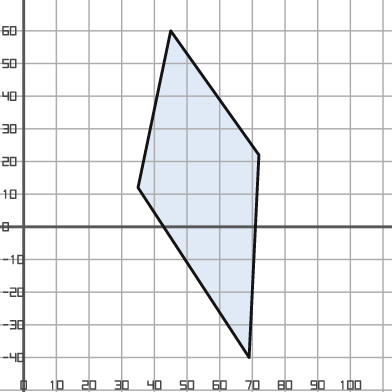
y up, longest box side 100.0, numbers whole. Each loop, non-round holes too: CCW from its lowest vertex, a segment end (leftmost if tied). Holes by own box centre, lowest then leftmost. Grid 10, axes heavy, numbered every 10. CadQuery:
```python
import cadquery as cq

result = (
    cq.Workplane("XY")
    .moveTo(69.0, -40.0)
    .lineTo(72.0, 22.0)
    .lineTo(45.0, 60.0)
    .lineTo(35.0, 12.0)
    .close()
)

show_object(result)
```